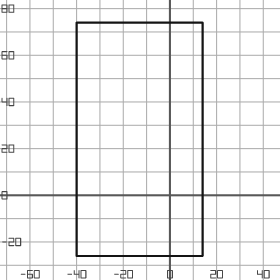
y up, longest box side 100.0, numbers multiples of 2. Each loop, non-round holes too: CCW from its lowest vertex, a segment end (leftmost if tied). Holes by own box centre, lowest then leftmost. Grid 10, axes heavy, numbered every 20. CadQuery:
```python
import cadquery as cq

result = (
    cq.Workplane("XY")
    .moveTo(-40.0, -26.0)
    .lineTo(14.0, -26.0)
    .lineTo(14.0, 74.0)
    .lineTo(-40.0, 74.0)
    .close()
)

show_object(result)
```